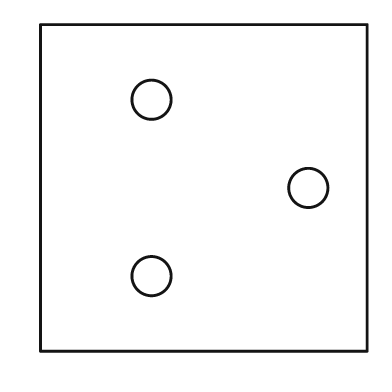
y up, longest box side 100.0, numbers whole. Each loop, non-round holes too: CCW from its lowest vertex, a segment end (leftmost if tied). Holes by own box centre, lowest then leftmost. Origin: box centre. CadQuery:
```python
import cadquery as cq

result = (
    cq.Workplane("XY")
    .moveTo(-50.0, -50.0)
    .lineTo(50.0, -50.0)
    .lineTo(50.0, 50.0)
    .lineTo(-50.0, 50.0)
    .close()
    .moveTo(-16.0, -27.0)
    .circle(6.0)
    .moveTo(32.0, 0.0)
    .circle(6.0)
    .moveTo(-16.0, 27.0)
    .circle(6.0)
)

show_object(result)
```